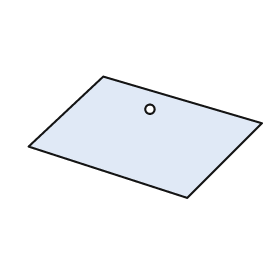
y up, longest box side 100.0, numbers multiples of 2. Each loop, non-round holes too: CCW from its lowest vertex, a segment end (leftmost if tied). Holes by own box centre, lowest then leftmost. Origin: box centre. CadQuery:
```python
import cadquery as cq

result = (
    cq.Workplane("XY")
    .moveTo(18.0, -26.0)
    .lineTo(50.0, 6.0)
    .lineTo(-18.0, 26.0)
    .lineTo(-50.0, -4.0)
    .close()
    .moveTo(2.0, 12.0)
    .circle(2.0)
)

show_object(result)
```